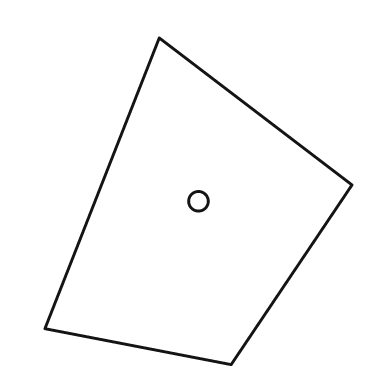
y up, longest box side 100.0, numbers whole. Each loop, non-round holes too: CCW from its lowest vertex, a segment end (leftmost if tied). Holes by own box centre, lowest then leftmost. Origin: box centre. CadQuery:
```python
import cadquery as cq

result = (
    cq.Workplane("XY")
    .moveTo(10.0, -50.0)
    .lineTo(47.0, 5.0)
    .lineTo(-12.0, 50.0)
    .lineTo(-47.0, -39.0)
    .close()
    .moveTo(0.0, 0.0)
    .circle(3.0)
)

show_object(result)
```